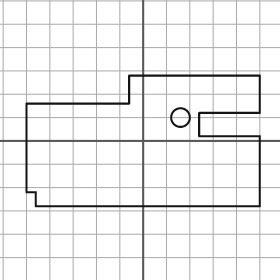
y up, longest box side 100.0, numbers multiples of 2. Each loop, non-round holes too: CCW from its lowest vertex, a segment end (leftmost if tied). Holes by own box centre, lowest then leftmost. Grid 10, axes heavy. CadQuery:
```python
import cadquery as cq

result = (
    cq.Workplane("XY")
    .moveTo(-46.0, -28.0)
    .lineTo(50.0, -28.0)
    .lineTo(50.0, 2.0)
    .lineTo(24.0, 2.0)
    .lineTo(24.0, 12.0)
    .lineTo(50.0, 12.0)
    .lineTo(50.0, 28.0)
    .lineTo(-6.0, 28.0)
    .lineTo(-6.0, 16.0)
    .lineTo(-50.0, 16.0)
    .lineTo(-50.0, -22.0)
    .lineTo(-46.0, -22.0)
    .close()
    .moveTo(16.0, 10.0)
    .circle(4.0)
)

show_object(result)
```